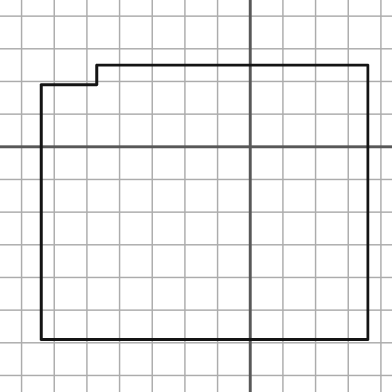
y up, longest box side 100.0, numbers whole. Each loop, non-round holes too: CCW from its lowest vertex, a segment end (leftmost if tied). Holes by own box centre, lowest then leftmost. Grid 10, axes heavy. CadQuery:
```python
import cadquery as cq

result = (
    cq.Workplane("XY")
    .moveTo(-64.0, -59.0)
    .lineTo(36.0, -59.0)
    .lineTo(36.0, 25.0)
    .lineTo(-47.0, 25.0)
    .lineTo(-47.0, 19.0)
    .lineTo(-64.0, 19.0)
    .close()
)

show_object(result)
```